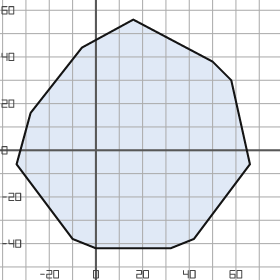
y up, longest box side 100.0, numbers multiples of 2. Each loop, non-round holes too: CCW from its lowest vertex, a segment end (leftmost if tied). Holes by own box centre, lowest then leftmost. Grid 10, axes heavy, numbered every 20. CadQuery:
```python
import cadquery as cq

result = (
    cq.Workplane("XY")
    .moveTo(0.0, -42.0)
    .lineTo(32.0, -42.0)
    .lineTo(42.0, -38.0)
    .lineTo(66.0, -6.0)
    .lineTo(58.0, 30.0)
    .lineTo(50.0, 38.0)
    .lineTo(16.0, 56.0)
    .lineTo(-6.0, 44.0)
    .lineTo(-28.0, 16.0)
    .lineTo(-34.0, -6.0)
    .lineTo(-10.0, -38.0)
    .close()
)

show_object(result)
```